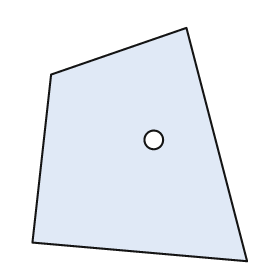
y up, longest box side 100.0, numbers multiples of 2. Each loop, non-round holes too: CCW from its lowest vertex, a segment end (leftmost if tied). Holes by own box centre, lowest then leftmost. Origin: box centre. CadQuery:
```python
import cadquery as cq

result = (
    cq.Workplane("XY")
    .moveTo(46.0, -50.0)
    .lineTo(20.0, 50.0)
    .lineTo(-38.0, 30.0)
    .lineTo(-46.0, -42.0)
    .close()
    .moveTo(6.0, 2.0)
    .circle(4.0)
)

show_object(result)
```